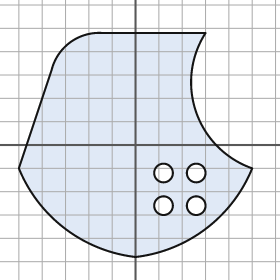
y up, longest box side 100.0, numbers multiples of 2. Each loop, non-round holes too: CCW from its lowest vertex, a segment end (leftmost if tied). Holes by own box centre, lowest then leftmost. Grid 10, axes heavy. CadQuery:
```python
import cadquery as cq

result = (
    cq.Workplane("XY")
    .moveTo(0.0, -48.0)
    .threePointArc((30.0, -36.0), (50.0, -10.0))
    .threePointArc((26.0, 14.0), (30.0, 48.0))
    .lineTo(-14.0, 48.0)
    .threePointArc((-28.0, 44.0), (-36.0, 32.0))
    .lineTo(-50.0, -10.0)
    .threePointArc((-30.0, -36.0), (0.0, -48.0))
    .close()
    .moveTo(12.0, -26.0)
    .circle(4.0)
    .moveTo(26.0, -26.0)
    .circle(4.0)
    .moveTo(12.0, -12.0)
    .circle(4.0)
    .moveTo(26.0, -12.0)
    .circle(4.0)
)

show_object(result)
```